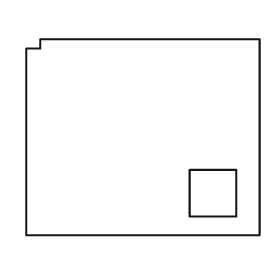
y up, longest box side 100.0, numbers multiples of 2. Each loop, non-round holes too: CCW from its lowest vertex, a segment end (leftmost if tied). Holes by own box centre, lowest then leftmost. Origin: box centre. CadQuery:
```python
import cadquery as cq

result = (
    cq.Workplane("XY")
    .moveTo(-50.0, -42.0)
    .lineTo(50.0, -42.0)
    .lineTo(50.0, 42.0)
    .lineTo(-44.0, 42.0)
    .lineTo(-44.0, 38.0)
    .lineTo(-50.0, 38.0)
    .close()
    .moveTo(20.0, -34.0)
    .lineTo(40.0, -34.0)
    .lineTo(40.0, -14.0)
    .lineTo(20.0, -14.0)
    .close()
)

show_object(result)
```